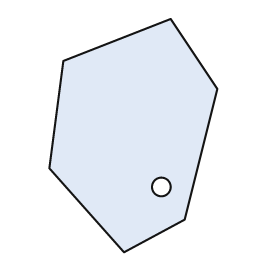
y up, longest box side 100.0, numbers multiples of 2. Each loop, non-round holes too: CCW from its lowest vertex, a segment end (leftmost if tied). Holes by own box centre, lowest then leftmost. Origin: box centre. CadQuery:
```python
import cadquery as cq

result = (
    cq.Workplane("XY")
    .moveTo(-4.0, -50.0)
    .lineTo(22.0, -36.0)
    .lineTo(36.0, 20.0)
    .lineTo(16.0, 50.0)
    .lineTo(-30.0, 32.0)
    .lineTo(-36.0, -14.0)
    .close()
    .moveTo(12.0, -22.0)
    .circle(4.0)
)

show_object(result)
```